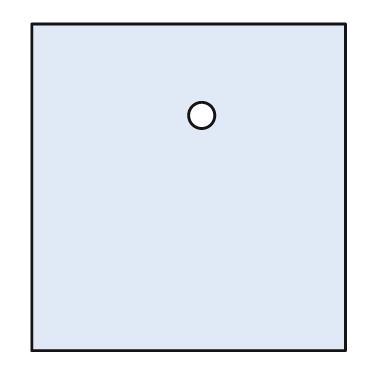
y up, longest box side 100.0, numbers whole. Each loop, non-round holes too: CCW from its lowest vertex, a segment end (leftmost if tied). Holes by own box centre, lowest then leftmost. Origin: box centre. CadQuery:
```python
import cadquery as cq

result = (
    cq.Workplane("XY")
    .moveTo(-48.0, -50.0)
    .lineTo(48.0, -50.0)
    .lineTo(48.0, 50.0)
    .lineTo(-48.0, 50.0)
    .close()
    .moveTo(4.0, 22.0)
    .circle(4.0)
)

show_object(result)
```